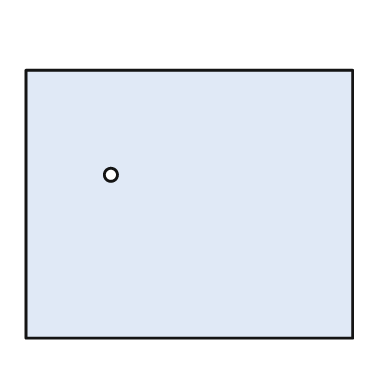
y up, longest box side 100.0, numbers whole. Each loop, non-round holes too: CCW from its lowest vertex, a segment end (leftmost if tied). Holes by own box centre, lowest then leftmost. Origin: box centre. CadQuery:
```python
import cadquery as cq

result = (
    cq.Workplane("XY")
    .moveTo(-50.0, -41.0)
    .lineTo(50.0, -41.0)
    .lineTo(50.0, 41.0)
    .lineTo(-50.0, 41.0)
    .close()
    .moveTo(-24.0, 9.0)
    .circle(2.0)
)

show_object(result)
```